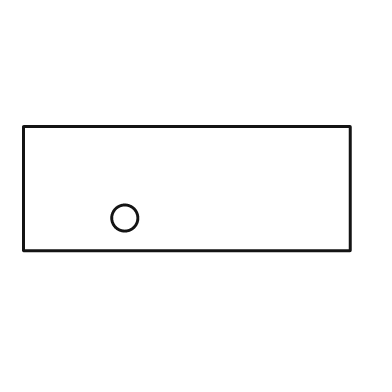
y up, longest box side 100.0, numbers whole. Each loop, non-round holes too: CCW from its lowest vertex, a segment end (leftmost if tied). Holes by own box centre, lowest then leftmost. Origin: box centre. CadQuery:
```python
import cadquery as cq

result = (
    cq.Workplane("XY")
    .moveTo(-50.0, -19.0)
    .lineTo(50.0, -19.0)
    .lineTo(50.0, 19.0)
    .lineTo(-50.0, 19.0)
    .close()
    .moveTo(-19.0, -9.0)
    .circle(4.0)
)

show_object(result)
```